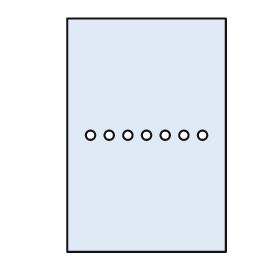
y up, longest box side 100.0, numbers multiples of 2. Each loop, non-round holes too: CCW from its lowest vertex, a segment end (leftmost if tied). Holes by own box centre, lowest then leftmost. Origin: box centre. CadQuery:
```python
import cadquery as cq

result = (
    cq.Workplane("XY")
    .moveTo(-34.0, -50.0)
    .lineTo(34.0, -50.0)
    .lineTo(34.0, 50.0)
    .lineTo(-34.0, 50.0)
    .close()
    .moveTo(-24.0, 0.0)
    .circle(2.0)
    .moveTo(-16.0, 0.0)
    .circle(2.0)
    .moveTo(-8.0, 0.0)
    .circle(2.0)
    .moveTo(0.0, 0.0)
    .circle(2.0)
    .moveTo(8.0, 0.0)
    .circle(2.0)
    .moveTo(16.0, 0.0)
    .circle(2.0)
    .moveTo(24.0, 0.0)
    .circle(2.0)
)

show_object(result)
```